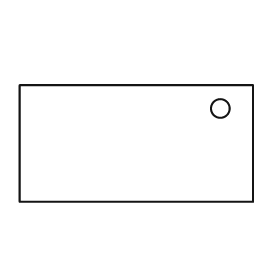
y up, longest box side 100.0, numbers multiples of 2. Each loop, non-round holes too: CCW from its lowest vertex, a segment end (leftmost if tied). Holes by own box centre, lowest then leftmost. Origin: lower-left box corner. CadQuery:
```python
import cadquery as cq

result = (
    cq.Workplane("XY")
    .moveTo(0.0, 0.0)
    .lineTo(100.0, 0.0)
    .lineTo(100.0, 50.0)
    .lineTo(0.0, 50.0)
    .close()
    .moveTo(86.0, 40.0)
    .circle(4.0)
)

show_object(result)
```